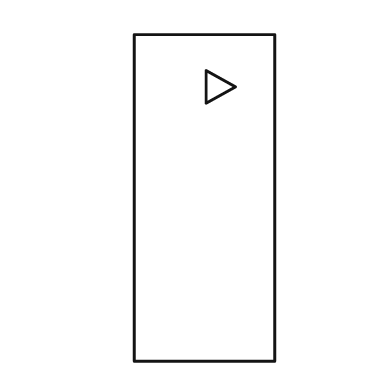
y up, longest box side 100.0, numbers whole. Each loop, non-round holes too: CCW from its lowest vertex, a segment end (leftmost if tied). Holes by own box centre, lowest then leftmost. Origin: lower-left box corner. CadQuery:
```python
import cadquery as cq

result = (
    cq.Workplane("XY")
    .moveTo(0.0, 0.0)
    .lineTo(43.0, 0.0)
    .lineTo(43.0, 100.0)
    .lineTo(0.0, 100.0)
    .close()
    .moveTo(22.0, 79.0)
    .lineTo(31.0, 84.0)
    .lineTo(22.0, 89.0)
    .close()
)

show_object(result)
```